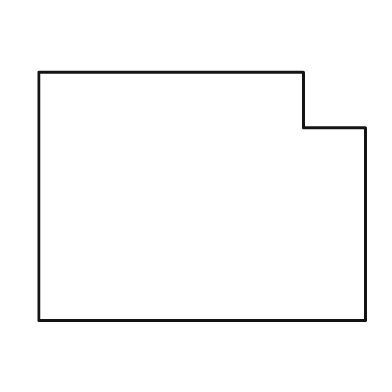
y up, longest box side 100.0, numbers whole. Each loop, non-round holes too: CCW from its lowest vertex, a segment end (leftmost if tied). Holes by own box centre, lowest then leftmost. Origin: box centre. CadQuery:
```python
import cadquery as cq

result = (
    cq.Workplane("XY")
    .moveTo(-50.0, -38.0)
    .lineTo(50.0, -38.0)
    .lineTo(50.0, 21.0)
    .lineTo(31.0, 21.0)
    .lineTo(31.0, 38.0)
    .lineTo(-50.0, 38.0)
    .close()
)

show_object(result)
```